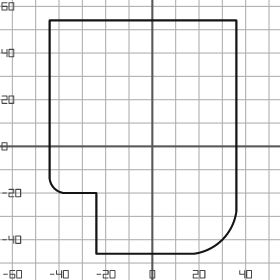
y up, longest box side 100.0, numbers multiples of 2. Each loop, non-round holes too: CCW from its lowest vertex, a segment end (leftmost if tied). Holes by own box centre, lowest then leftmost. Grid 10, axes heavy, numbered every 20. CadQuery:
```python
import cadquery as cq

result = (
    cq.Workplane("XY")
    .moveTo(-24.0, -46.0)
    .lineTo(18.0, -46.0)
    .threePointArc((30.0, -40.0), (36.0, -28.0))
    .lineTo(36.0, 54.0)
    .lineTo(-44.0, 54.0)
    .lineTo(-44.0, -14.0)
    .threePointArc((-42.0, -18.0), (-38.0, -20.0))
    .lineTo(-24.0, -20.0)
    .close()
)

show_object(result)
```